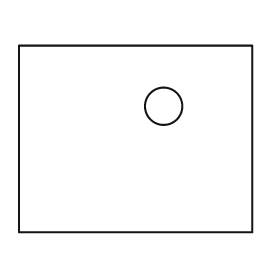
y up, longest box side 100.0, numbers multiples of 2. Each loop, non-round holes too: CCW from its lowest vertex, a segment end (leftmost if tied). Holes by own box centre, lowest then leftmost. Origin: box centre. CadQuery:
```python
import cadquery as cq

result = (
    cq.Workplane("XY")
    .moveTo(-50.0, -40.0)
    .lineTo(50.0, -40.0)
    .lineTo(50.0, 40.0)
    .lineTo(-50.0, 40.0)
    .close()
    .moveTo(12.0, 14.0)
    .circle(8.0)
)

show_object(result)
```